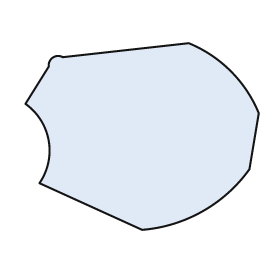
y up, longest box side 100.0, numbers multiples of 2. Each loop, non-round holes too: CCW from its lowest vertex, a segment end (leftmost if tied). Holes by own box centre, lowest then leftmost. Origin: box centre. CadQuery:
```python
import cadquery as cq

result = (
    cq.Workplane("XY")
    .moveTo(0.0, -40.0)
    .threePointArc((26.0, -32.0), (46.0, -14.0))
    .lineTo(50.0, 10.0)
    .threePointArc((38.0, 28.0), (20.0, 40.0))
    .lineTo(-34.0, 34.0)
    .threePointArc((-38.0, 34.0), (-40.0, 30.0))
    .lineTo(-50.0, 14.0)
    .threePointArc((-40.0, -2.0), (-44.0, -20.0))
    .close()
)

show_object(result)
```